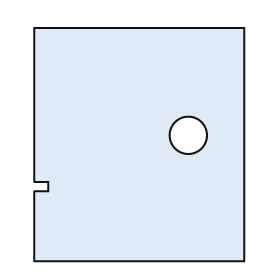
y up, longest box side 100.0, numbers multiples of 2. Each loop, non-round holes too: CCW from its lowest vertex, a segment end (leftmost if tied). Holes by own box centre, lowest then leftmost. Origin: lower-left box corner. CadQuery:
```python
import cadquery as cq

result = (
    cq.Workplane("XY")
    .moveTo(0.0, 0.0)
    .lineTo(90.0, 0.0)
    .lineTo(90.0, 100.0)
    .lineTo(0.0, 100.0)
    .lineTo(0.0, 34.0)
    .lineTo(6.0, 34.0)
    .lineTo(6.0, 30.0)
    .lineTo(0.0, 30.0)
    .close()
    .moveTo(66.0, 54.0)
    .circle(8.0)
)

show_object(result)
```